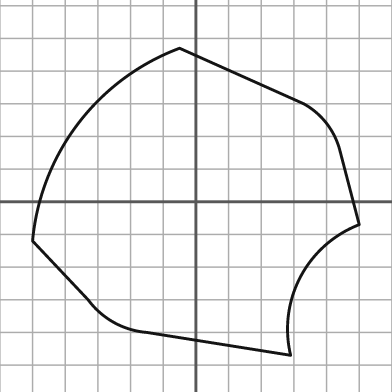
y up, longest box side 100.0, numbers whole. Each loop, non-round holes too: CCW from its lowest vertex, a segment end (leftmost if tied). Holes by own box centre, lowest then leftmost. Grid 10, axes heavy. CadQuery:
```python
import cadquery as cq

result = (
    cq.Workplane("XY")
    .moveTo(29.0, -47.0)
    .threePointArc((32.0, -23.0), (50.0, -7.0))
    .lineTo(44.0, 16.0)
    .threePointArc((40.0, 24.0), (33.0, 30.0))
    .lineTo(-5.0, 47.0)
    .threePointArc((-36.0, 24.0), (-50.0, -12.0))
    .lineTo(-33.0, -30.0)
    .threePointArc((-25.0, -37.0), (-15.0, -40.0))
    .close()
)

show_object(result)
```